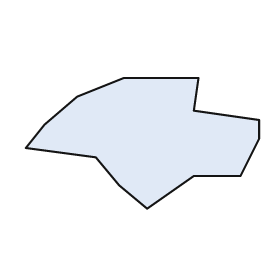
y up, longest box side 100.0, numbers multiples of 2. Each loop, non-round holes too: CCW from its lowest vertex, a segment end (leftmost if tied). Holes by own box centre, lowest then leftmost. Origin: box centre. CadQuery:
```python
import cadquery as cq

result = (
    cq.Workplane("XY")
    .moveTo(2.0, -28.0)
    .lineTo(22.0, -14.0)
    .lineTo(42.0, -14.0)
    .lineTo(50.0, 2.0)
    .lineTo(50.0, 10.0)
    .lineTo(22.0, 14.0)
    .lineTo(24.0, 28.0)
    .lineTo(-8.0, 28.0)
    .lineTo(-28.0, 20.0)
    .lineTo(-42.0, 8.0)
    .lineTo(-50.0, -2.0)
    .lineTo(-20.0, -6.0)
    .lineTo(-10.0, -18.0)
    .close()
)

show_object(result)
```